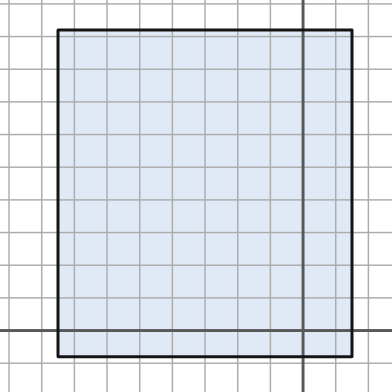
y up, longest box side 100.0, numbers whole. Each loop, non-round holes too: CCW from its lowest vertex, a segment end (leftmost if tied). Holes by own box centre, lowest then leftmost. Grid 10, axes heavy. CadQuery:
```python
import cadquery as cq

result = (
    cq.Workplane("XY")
    .moveTo(-75.0, -8.0)
    .lineTo(15.0, -8.0)
    .lineTo(15.0, 92.0)
    .lineTo(-75.0, 92.0)
    .close()
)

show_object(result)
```